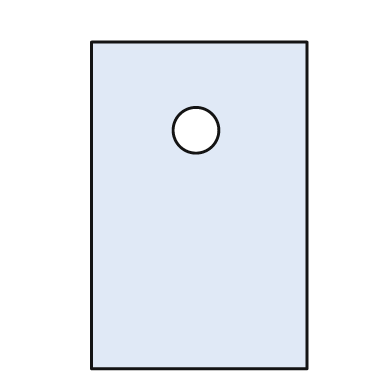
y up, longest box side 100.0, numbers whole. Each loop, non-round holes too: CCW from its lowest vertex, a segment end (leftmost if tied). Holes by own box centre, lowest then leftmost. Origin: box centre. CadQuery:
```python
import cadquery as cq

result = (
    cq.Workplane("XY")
    .moveTo(-33.0, -50.0)
    .lineTo(33.0, -50.0)
    .lineTo(33.0, 50.0)
    .lineTo(-33.0, 50.0)
    .close()
    .moveTo(-1.0, 23.0)
    .circle(7.0)
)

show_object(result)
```